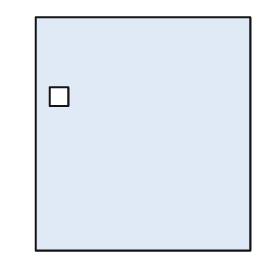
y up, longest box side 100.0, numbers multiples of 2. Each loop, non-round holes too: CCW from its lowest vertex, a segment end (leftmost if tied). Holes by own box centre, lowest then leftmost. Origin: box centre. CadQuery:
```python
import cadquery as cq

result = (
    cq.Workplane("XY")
    .moveTo(-46.0, -50.0)
    .lineTo(46.0, -50.0)
    .lineTo(46.0, 50.0)
    .lineTo(-46.0, 50.0)
    .close()
    .moveTo(-40.0, 12.0)
    .lineTo(-32.0, 12.0)
    .lineTo(-32.0, 20.0)
    .lineTo(-40.0, 20.0)
    .close()
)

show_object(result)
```